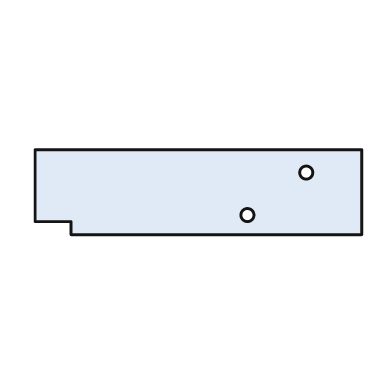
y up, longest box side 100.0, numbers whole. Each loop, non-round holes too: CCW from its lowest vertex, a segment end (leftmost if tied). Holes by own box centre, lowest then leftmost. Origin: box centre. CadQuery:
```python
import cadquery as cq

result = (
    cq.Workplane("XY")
    .moveTo(-39.0, -13.0)
    .lineTo(50.0, -13.0)
    .lineTo(50.0, 13.0)
    .lineTo(-50.0, 13.0)
    .lineTo(-50.0, -9.0)
    .lineTo(-39.0, -9.0)
    .close()
    .moveTo(15.0, -7.0)
    .circle(2.0)
    .moveTo(33.0, 6.0)
    .circle(2.0)
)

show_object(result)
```